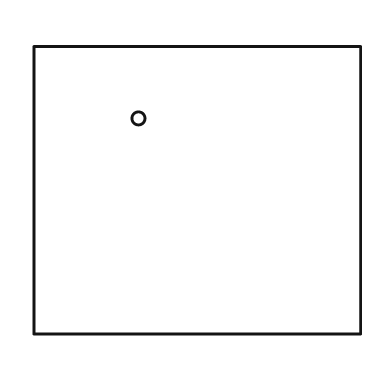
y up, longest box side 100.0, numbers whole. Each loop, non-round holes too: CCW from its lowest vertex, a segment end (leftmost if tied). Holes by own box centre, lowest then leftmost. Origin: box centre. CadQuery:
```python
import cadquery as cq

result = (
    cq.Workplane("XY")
    .moveTo(-50.0, -44.0)
    .lineTo(50.0, -44.0)
    .lineTo(50.0, 44.0)
    .lineTo(-50.0, 44.0)
    .close()
    .moveTo(-18.0, 22.0)
    .circle(2.0)
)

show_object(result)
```